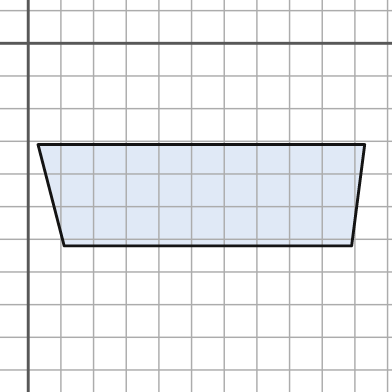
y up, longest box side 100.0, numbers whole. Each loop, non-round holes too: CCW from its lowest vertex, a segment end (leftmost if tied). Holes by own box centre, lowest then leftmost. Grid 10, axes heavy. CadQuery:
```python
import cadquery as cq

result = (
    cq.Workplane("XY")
    .moveTo(11.0, -62.0)
    .lineTo(99.0, -62.0)
    .lineTo(103.0, -31.0)
    .lineTo(3.0, -31.0)
    .close()
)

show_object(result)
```